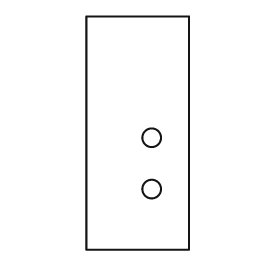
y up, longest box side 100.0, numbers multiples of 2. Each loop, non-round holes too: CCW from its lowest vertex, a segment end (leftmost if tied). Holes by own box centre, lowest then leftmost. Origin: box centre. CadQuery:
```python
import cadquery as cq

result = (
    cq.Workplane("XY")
    .moveTo(-22.0, -50.0)
    .lineTo(22.0, -50.0)
    .lineTo(22.0, 50.0)
    .lineTo(-22.0, 50.0)
    .close()
    .moveTo(6.0, -24.0)
    .circle(4.0)
    .moveTo(6.0, -2.0)
    .circle(4.0)
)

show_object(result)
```